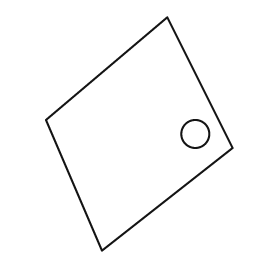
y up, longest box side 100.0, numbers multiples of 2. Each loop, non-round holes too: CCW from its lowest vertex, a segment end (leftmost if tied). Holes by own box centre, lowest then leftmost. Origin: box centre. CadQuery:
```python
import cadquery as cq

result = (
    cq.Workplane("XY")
    .moveTo(-16.0, -50.0)
    .lineTo(40.0, -6.0)
    .lineTo(12.0, 50.0)
    .lineTo(-40.0, 6.0)
    .close()
    .moveTo(24.0, 0.0)
    .circle(6.0)
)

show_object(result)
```